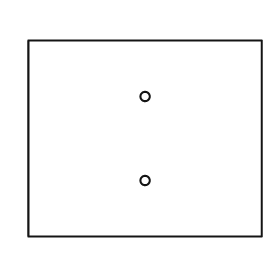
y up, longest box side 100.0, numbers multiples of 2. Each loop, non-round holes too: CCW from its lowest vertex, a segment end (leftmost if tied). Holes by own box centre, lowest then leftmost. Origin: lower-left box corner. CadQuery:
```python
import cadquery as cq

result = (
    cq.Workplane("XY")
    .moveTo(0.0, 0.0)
    .lineTo(100.0, 0.0)
    .lineTo(100.0, 84.0)
    .lineTo(0.0, 84.0)
    .close()
    .moveTo(50.0, 24.0)
    .circle(2.0)
    .moveTo(50.0, 60.0)
    .circle(2.0)
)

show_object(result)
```